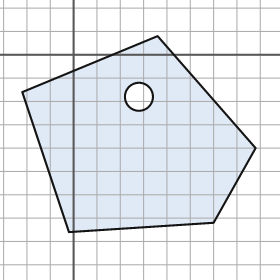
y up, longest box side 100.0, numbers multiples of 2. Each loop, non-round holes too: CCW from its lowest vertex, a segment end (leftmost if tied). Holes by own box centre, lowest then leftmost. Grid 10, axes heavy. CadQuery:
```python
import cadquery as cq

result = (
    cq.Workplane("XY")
    .moveTo(-2.0, -76.0)
    .lineTo(60.0, -72.0)
    .lineTo(78.0, -40.0)
    .lineTo(36.0, 8.0)
    .lineTo(-22.0, -16.0)
    .close()
    .moveTo(28.0, -18.0)
    .circle(6.0)
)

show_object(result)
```